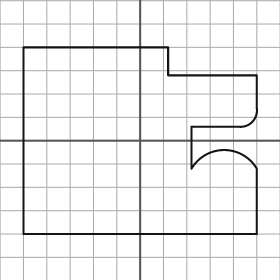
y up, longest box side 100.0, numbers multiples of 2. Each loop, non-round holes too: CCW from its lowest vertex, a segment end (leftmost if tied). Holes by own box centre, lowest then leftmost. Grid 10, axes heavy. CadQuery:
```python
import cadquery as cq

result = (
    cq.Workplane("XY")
    .moveTo(-50.0, -40.0)
    .lineTo(50.0, -40.0)
    .lineTo(50.0, -12.0)
    .threePointArc((36.0, -4.0), (22.0, -12.0))
    .lineTo(22.0, 6.0)
    .lineTo(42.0, 6.0)
    .threePointArc((48.0, 8.0), (50.0, 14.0))
    .lineTo(50.0, 28.0)
    .lineTo(12.0, 28.0)
    .lineTo(12.0, 40.0)
    .lineTo(-50.0, 40.0)
    .close()
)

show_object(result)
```